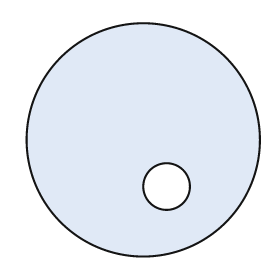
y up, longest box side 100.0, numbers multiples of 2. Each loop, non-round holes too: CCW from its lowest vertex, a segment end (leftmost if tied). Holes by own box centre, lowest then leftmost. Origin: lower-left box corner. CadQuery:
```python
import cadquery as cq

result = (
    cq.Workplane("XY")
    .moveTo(50.0, 50.0)
    .circle(50.0)
    .moveTo(60.0, 30.0)
    .circle(10.0)
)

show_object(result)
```